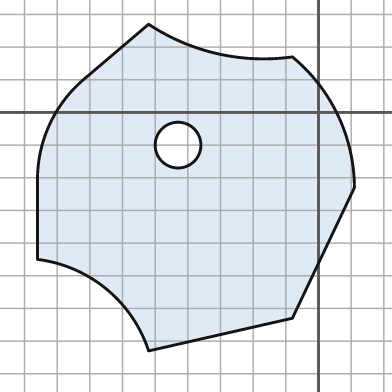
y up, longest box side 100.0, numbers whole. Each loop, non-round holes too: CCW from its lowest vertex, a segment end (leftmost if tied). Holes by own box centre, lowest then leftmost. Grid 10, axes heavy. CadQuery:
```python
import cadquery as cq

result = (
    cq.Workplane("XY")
    .moveTo(-52.0, -73.0)
    .lineTo(-8.0, -63.0)
    .lineTo(11.0, -23.0)
    .threePointArc((6.0, -1.0), (-8.0, 17.0))
    .threePointArc((-31.0, 18.0), (-52.0, 27.0))
    .lineTo(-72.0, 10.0)
    .threePointArc((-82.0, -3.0), (-86.0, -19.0))
    .lineTo(-86.0, -45.0)
    .threePointArc((-65.0, -54.0), (-52.0, -73.0))
    .close()
    .moveTo(-43.0, -10.0)
    .circle(7.0)
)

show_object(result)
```